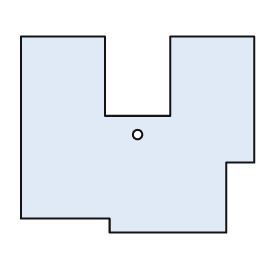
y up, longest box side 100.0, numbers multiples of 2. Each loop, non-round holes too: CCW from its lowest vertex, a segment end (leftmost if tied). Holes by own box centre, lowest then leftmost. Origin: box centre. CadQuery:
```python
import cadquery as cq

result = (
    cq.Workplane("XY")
    .moveTo(-12.0, -42.0)
    .lineTo(38.0, -42.0)
    .lineTo(38.0, -12.0)
    .lineTo(50.0, -12.0)
    .lineTo(50.0, 42.0)
    .lineTo(14.0, 42.0)
    .lineTo(14.0, 8.0)
    .lineTo(-14.0, 8.0)
    .lineTo(-14.0, 42.0)
    .lineTo(-50.0, 42.0)
    .lineTo(-50.0, -36.0)
    .lineTo(-12.0, -36.0)
    .close()
    .moveTo(0.0, 0.0)
    .circle(2.0)
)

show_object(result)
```